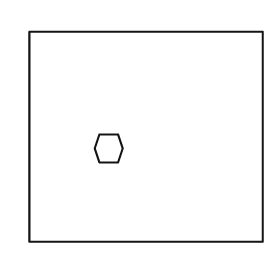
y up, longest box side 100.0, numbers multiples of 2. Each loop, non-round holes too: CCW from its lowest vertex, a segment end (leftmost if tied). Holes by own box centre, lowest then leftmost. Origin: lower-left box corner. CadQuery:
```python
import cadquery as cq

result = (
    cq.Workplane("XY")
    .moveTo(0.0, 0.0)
    .lineTo(100.0, 0.0)
    .lineTo(100.0, 90.0)
    .lineTo(0.0, 90.0)
    .close()
    .moveTo(30.0, 34.0)
    .lineTo(38.0, 34.0)
    .lineTo(40.0, 40.0)
    .lineTo(38.0, 46.0)
    .lineTo(30.0, 46.0)
    .lineTo(28.0, 40.0)
    .close()
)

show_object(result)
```